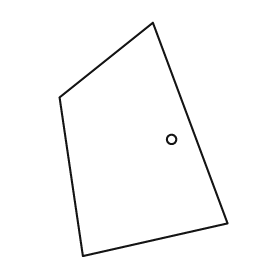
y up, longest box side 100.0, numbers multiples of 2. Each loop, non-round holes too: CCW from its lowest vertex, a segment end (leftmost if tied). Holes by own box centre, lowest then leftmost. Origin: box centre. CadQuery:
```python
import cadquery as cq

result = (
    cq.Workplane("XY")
    .moveTo(-26.0, -50.0)
    .lineTo(36.0, -36.0)
    .lineTo(4.0, 50.0)
    .lineTo(-36.0, 18.0)
    .close()
    .moveTo(12.0, 0.0)
    .circle(2.0)
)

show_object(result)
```